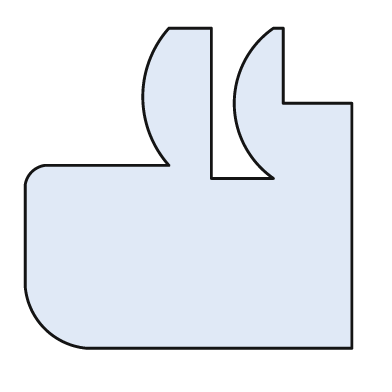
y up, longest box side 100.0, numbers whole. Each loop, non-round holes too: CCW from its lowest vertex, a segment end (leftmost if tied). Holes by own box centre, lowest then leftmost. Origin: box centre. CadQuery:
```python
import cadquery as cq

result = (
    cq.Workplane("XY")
    .moveTo(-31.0, -49.0)
    .lineTo(50.0, -49.0)
    .lineTo(50.0, 26.0)
    .lineTo(29.0, 26.0)
    .lineTo(29.0, 49.0)
    .lineTo(26.0, 49.0)
    .threePointArc((14.0, 26.0), (26.0, 3.0))
    .lineTo(7.0, 3.0)
    .lineTo(7.0, 49.0)
    .lineTo(-6.0, 49.0)
    .threePointArc((-14.0, 28.0), (-6.0, 7.0))
    .lineTo(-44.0, 7.0)
    .threePointArc((-48.0, 5.0), (-50.0, 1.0))
    .lineTo(-50.0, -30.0)
    .threePointArc((-44.0, -43.0), (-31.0, -49.0))
    .close()
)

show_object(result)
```